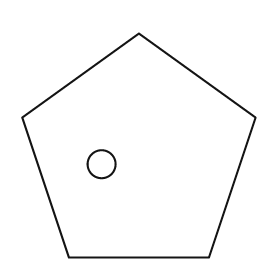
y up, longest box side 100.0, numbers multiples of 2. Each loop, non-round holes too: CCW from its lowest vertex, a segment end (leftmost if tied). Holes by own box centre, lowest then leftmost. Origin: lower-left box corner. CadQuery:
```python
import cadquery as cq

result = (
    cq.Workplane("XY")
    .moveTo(20.0, 0.0)
    .lineTo(80.0, 0.0)
    .lineTo(100.0, 60.0)
    .lineTo(50.0, 96.0)
    .lineTo(0.0, 60.0)
    .close()
    .moveTo(34.0, 40.0)
    .circle(6.0)
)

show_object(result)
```